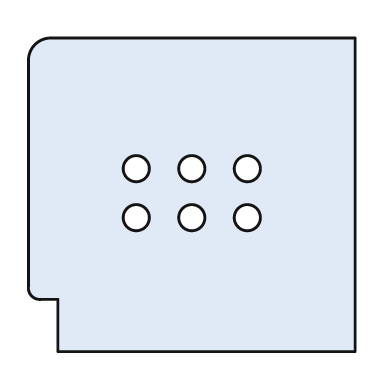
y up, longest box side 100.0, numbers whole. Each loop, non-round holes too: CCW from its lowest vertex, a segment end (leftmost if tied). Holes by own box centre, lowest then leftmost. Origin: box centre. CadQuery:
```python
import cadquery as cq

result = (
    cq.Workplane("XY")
    .moveTo(-41.0, -48.0)
    .lineTo(50.0, -48.0)
    .lineTo(50.0, 48.0)
    .lineTo(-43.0, 48.0)
    .threePointArc((-48.0, 46.0), (-50.0, 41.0))
    .lineTo(-50.0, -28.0)
    .threePointArc((-49.0, -31.0), (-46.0, -32.0))
    .lineTo(-41.0, -32.0)
    .close()
    .moveTo(-17.0, -7.0)
    .circle(4.0)
    .moveTo(0.0, -7.0)
    .circle(4.0)
    .moveTo(17.0, -7.0)
    .circle(4.0)
    .moveTo(-17.0, 8.0)
    .circle(4.0)
    .moveTo(0.0, 8.0)
    .circle(4.0)
    .moveTo(17.0, 8.0)
    .circle(4.0)
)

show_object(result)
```